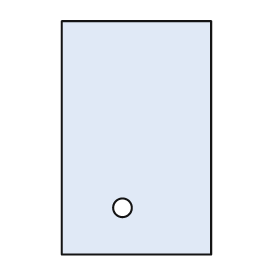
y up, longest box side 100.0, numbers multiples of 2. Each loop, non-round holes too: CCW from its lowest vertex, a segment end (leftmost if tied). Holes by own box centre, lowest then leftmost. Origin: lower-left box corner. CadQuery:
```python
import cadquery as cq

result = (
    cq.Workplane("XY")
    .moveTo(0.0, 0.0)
    .lineTo(64.0, 0.0)
    .lineTo(64.0, 100.0)
    .lineTo(0.0, 100.0)
    .close()
    .moveTo(26.0, 20.0)
    .circle(4.0)
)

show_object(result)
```